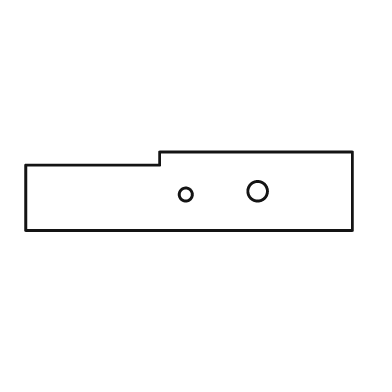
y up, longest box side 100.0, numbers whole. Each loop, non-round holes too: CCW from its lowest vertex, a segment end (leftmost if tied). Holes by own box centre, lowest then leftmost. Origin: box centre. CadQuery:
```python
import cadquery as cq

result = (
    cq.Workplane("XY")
    .moveTo(-50.0, -12.0)
    .lineTo(50.0, -12.0)
    .lineTo(50.0, 12.0)
    .lineTo(-9.0, 12.0)
    .lineTo(-9.0, 8.0)
    .lineTo(-50.0, 8.0)
    .close()
    .moveTo(-1.0, -1.0)
    .circle(2.0)
    .moveTo(21.0, 0.0)
    .circle(3.0)
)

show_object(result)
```